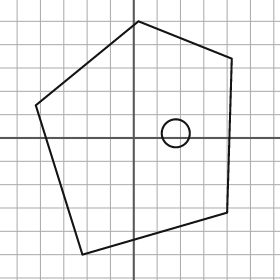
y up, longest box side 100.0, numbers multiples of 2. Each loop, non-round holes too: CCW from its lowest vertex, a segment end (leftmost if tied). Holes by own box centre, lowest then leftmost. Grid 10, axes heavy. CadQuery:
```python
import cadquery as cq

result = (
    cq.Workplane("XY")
    .moveTo(-22.0, -50.0)
    .lineTo(40.0, -32.0)
    .lineTo(42.0, 34.0)
    .lineTo(2.0, 50.0)
    .lineTo(-42.0, 14.0)
    .close()
    .moveTo(18.0, 2.0)
    .circle(6.0)
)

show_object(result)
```